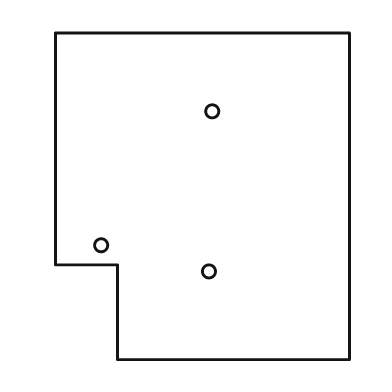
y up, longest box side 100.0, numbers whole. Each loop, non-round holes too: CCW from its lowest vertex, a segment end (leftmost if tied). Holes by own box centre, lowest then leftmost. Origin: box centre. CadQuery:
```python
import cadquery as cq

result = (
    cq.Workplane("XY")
    .moveTo(-26.0, -50.0)
    .lineTo(45.0, -50.0)
    .lineTo(45.0, 50.0)
    .lineTo(-45.0, 50.0)
    .lineTo(-45.0, -21.0)
    .lineTo(-26.0, -21.0)
    .close()
    .moveTo(2.0, -23.0)
    .circle(2.0)
    .moveTo(-31.0, -15.0)
    .circle(2.0)
    .moveTo(3.0, 26.0)
    .circle(2.0)
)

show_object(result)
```